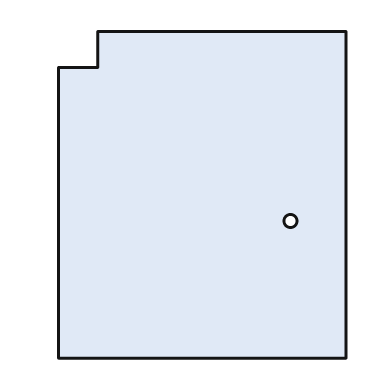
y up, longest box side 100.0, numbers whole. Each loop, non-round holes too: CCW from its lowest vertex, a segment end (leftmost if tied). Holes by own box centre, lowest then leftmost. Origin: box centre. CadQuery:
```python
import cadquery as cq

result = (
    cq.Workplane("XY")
    .moveTo(-44.0, -50.0)
    .lineTo(44.0, -50.0)
    .lineTo(44.0, 50.0)
    .lineTo(-32.0, 50.0)
    .lineTo(-32.0, 39.0)
    .lineTo(-44.0, 39.0)
    .close()
    .moveTo(27.0, -8.0)
    .circle(2.0)
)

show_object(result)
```